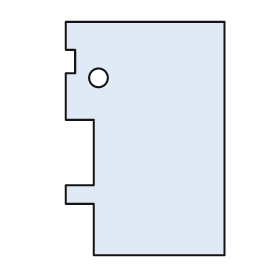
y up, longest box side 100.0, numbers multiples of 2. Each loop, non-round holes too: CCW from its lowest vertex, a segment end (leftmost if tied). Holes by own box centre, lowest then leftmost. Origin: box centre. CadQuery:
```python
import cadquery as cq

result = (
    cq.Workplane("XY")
    .moveTo(-22.0, -50.0)
    .lineTo(34.0, -50.0)
    .lineTo(34.0, 50.0)
    .lineTo(-34.0, 50.0)
    .lineTo(-34.0, 38.0)
    .lineTo(-30.0, 38.0)
    .lineTo(-30.0, 28.0)
    .lineTo(-34.0, 28.0)
    .lineTo(-34.0, 8.0)
    .lineTo(-22.0, 8.0)
    .lineTo(-22.0, -20.0)
    .lineTo(-34.0, -20.0)
    .lineTo(-34.0, -28.0)
    .lineTo(-22.0, -28.0)
    .close()
    .moveTo(-20.0, 26.0)
    .circle(4.0)
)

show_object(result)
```